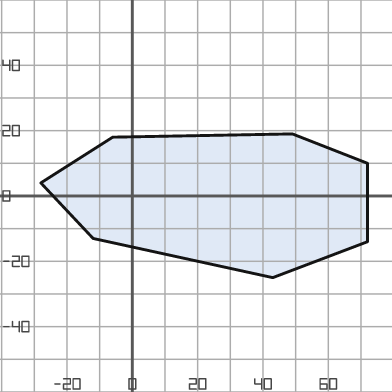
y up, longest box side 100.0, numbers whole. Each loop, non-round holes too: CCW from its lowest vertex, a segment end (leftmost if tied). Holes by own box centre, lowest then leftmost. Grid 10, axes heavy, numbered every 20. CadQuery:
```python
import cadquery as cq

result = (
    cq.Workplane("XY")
    .moveTo(43.0, -25.0)
    .lineTo(72.0, -14.0)
    .lineTo(72.0, 10.0)
    .lineTo(49.0, 19.0)
    .lineTo(-6.0, 18.0)
    .lineTo(-28.0, 4.0)
    .lineTo(-12.0, -13.0)
    .close()
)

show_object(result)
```